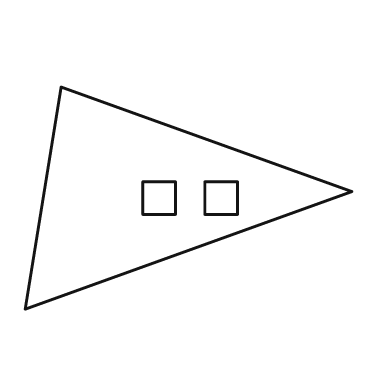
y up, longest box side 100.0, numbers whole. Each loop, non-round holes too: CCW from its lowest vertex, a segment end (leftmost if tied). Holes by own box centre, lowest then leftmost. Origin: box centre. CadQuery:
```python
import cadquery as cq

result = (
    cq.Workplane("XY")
    .moveTo(-50.0, -34.0)
    .lineTo(50.0, 2.0)
    .lineTo(-39.0, 34.0)
    .close()
    .moveTo(-14.0, -5.0)
    .lineTo(-4.0, -5.0)
    .lineTo(-4.0, 5.0)
    .lineTo(-14.0, 5.0)
    .close()
    .moveTo(5.0, -5.0)
    .lineTo(15.0, -5.0)
    .lineTo(15.0, 5.0)
    .lineTo(5.0, 5.0)
    .close()
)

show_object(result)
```